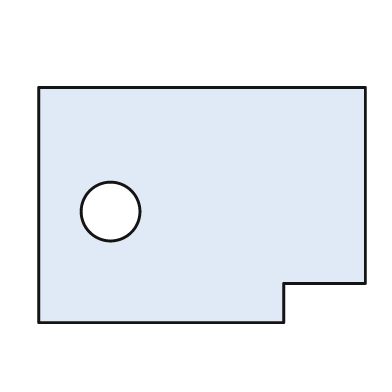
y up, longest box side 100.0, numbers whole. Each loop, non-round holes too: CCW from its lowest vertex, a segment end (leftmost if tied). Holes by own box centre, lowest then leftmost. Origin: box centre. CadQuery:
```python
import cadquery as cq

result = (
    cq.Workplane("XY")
    .moveTo(-50.0, -36.0)
    .lineTo(25.0, -36.0)
    .lineTo(25.0, -24.0)
    .lineTo(50.0, -24.0)
    .lineTo(50.0, 36.0)
    .lineTo(-50.0, 36.0)
    .close()
    .moveTo(-28.0, -2.0)
    .circle(9.0)
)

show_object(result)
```